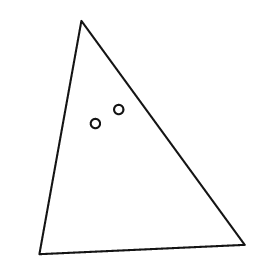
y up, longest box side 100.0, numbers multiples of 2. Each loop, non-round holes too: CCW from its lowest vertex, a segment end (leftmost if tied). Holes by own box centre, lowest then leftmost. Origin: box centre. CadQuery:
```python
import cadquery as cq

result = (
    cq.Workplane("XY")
    .moveTo(-44.0, -50.0)
    .lineTo(44.0, -46.0)
    .lineTo(-26.0, 50.0)
    .close()
    .moveTo(-20.0, 6.0)
    .circle(2.0)
    .moveTo(-10.0, 12.0)
    .circle(2.0)
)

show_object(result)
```